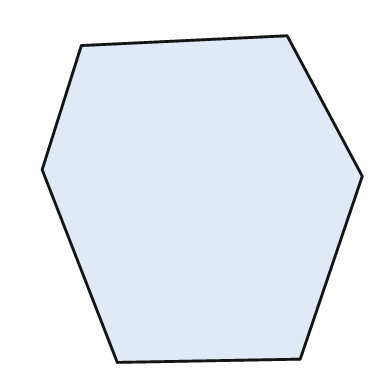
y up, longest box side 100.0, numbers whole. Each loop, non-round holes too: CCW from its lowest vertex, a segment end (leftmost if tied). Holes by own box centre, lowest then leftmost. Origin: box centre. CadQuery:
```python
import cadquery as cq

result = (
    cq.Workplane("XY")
    .moveTo(-26.0, -50.0)
    .lineTo(30.0, -49.0)
    .lineTo(49.0, 7.0)
    .lineTo(26.0, 50.0)
    .lineTo(-37.0, 47.0)
    .lineTo(-49.0, 9.0)
    .close()
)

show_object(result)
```